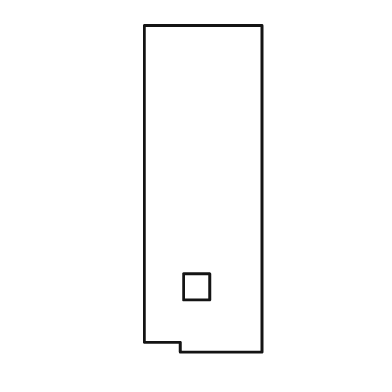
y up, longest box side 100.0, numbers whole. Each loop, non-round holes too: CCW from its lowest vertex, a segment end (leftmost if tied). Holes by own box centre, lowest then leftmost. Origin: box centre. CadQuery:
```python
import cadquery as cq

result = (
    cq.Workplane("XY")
    .moveTo(-7.0, -50.0)
    .lineTo(18.0, -50.0)
    .lineTo(18.0, 50.0)
    .lineTo(-18.0, 50.0)
    .lineTo(-18.0, -47.0)
    .lineTo(-7.0, -47.0)
    .close()
    .moveTo(-6.0, -34.0)
    .lineTo(2.0, -34.0)
    .lineTo(2.0, -26.0)
    .lineTo(-6.0, -26.0)
    .close()
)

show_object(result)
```